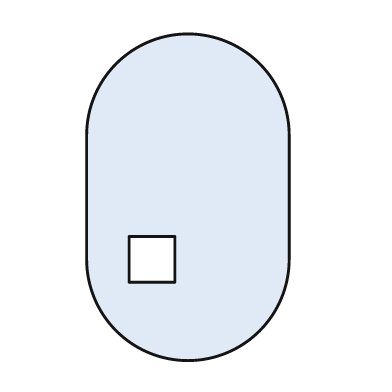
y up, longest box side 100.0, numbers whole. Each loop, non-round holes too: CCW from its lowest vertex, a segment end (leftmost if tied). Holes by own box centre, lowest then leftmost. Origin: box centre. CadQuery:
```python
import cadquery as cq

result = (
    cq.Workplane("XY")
    .moveTo(-31.0, -19.0)
    .threePointArc((0.0, -50.0), (31.0, -19.0))
    .lineTo(31.0, 19.0)
    .threePointArc((0.0, 50.0), (-31.0, 19.0))
    .close()
    .moveTo(-18.0, -26.0)
    .lineTo(-4.0, -26.0)
    .lineTo(-4.0, -12.0)
    .lineTo(-18.0, -12.0)
    .close()
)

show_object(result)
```